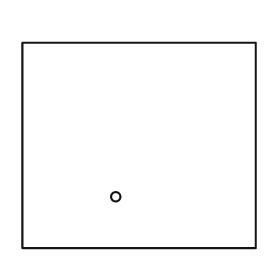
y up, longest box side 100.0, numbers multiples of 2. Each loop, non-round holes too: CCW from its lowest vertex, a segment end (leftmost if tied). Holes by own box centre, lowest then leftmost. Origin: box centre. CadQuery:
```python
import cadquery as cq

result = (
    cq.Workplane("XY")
    .moveTo(-50.0, -44.0)
    .lineTo(50.0, -44.0)
    .lineTo(50.0, 44.0)
    .lineTo(-50.0, 44.0)
    .close()
    .moveTo(-10.0, -22.0)
    .circle(2.0)
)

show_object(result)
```